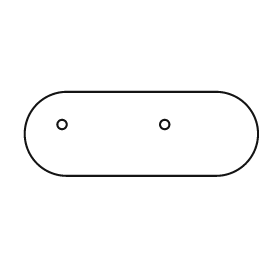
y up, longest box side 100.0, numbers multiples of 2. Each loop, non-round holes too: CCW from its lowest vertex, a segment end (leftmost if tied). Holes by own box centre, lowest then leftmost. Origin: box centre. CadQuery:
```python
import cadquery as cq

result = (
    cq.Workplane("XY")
    .moveTo(-32.0, -18.0)
    .lineTo(32.0, -18.0)
    .threePointArc((50.0, 0.0), (32.0, 18.0))
    .lineTo(-32.0, 18.0)
    .threePointArc((-50.0, 0.0), (-32.0, -18.0))
    .close()
    .moveTo(-34.0, 4.0)
    .circle(2.0)
    .moveTo(10.0, 4.0)
    .circle(2.0)
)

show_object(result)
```